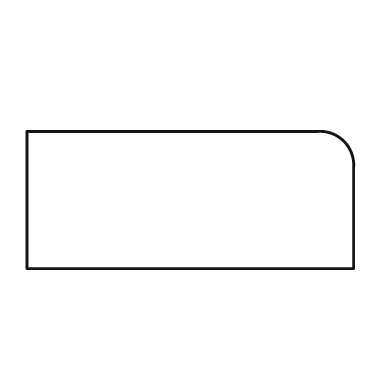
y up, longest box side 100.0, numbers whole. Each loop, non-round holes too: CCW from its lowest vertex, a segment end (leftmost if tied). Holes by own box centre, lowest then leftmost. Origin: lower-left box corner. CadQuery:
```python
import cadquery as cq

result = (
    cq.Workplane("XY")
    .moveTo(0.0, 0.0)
    .lineTo(100.0, 0.0)
    .lineTo(100.0, 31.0)
    .threePointArc((97.0, 39.0), (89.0, 42.0))
    .lineTo(0.0, 42.0)
    .close()
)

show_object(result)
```